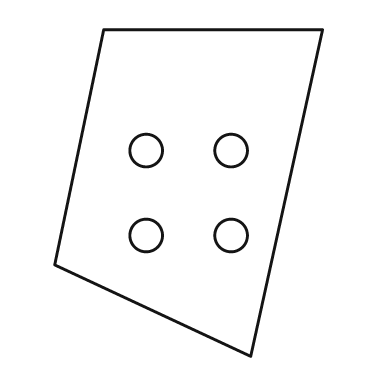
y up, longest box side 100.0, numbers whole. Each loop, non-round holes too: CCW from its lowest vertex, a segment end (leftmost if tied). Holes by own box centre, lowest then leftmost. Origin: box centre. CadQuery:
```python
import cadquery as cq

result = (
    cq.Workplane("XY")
    .moveTo(19.0, -50.0)
    .lineTo(41.0, 50.0)
    .lineTo(-26.0, 50.0)
    .lineTo(-41.0, -22.0)
    .close()
    .moveTo(-13.0, -13.0)
    .circle(5.0)
    .moveTo(13.0, -13.0)
    .circle(5.0)
    .moveTo(-13.0, 13.0)
    .circle(5.0)
    .moveTo(13.0, 13.0)
    .circle(5.0)
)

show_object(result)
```